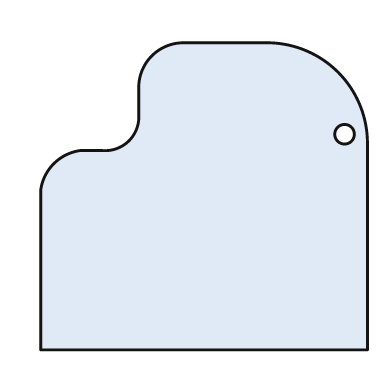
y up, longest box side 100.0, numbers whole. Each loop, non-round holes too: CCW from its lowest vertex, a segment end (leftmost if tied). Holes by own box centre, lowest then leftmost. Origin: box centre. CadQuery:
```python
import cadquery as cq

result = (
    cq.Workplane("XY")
    .moveTo(-50.0, -47.0)
    .lineTo(50.0, -47.0)
    .lineTo(50.0, 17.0)
    .threePointArc((41.0, 38.0), (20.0, 47.0))
    .lineTo(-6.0, 47.0)
    .threePointArc((-16.0, 43.0), (-20.0, 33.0))
    .lineTo(-20.0, 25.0)
    .threePointArc((-23.0, 17.0), (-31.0, 14.0))
    .lineTo(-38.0, 14.0)
    .threePointArc((-46.0, 10.0), (-50.0, 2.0))
    .close()
    .moveTo(43.0, 19.0)
    .circle(3.0)
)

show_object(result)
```